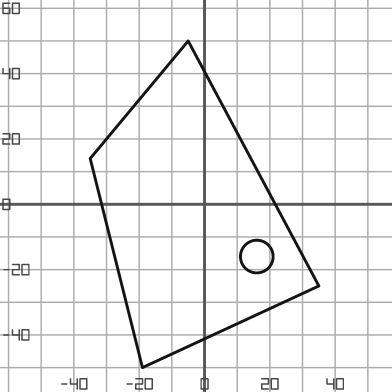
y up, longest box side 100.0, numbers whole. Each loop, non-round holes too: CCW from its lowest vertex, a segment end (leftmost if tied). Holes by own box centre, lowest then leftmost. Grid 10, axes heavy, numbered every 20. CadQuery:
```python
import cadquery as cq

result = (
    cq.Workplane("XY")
    .moveTo(-19.0, -50.0)
    .lineTo(35.0, -25.0)
    .lineTo(-5.0, 50.0)
    .lineTo(-35.0, 14.0)
    .close()
    .moveTo(16.0, -16.0)
    .circle(5.0)
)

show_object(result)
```